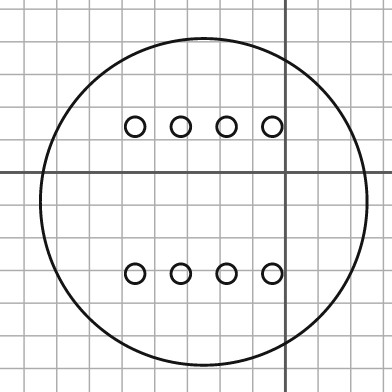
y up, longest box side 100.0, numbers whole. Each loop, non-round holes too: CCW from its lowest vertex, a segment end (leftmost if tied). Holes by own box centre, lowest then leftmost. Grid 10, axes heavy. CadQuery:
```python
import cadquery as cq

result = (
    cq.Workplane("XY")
    .moveTo(-25.0, -9.0)
    .circle(50.0)
    .moveTo(-46.0, -31.0)
    .circle(3.0)
    .moveTo(-32.0, -31.0)
    .circle(3.0)
    .moveTo(-18.0, -31.0)
    .circle(3.0)
    .moveTo(-4.0, -31.0)
    .circle(3.0)
    .moveTo(-46.0, 14.0)
    .circle(3.0)
    .moveTo(-32.0, 14.0)
    .circle(3.0)
    .moveTo(-18.0, 14.0)
    .circle(3.0)
    .moveTo(-4.0, 14.0)
    .circle(3.0)
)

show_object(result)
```